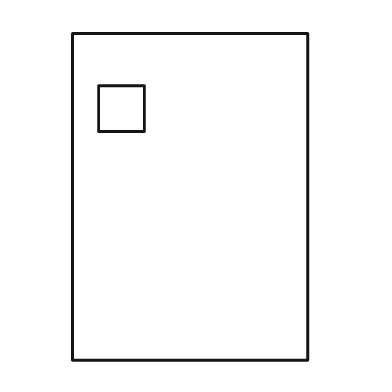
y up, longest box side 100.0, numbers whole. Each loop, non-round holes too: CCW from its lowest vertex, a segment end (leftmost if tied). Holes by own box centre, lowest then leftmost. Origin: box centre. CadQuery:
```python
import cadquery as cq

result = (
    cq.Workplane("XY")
    .moveTo(-36.0, -50.0)
    .lineTo(36.0, -50.0)
    .lineTo(36.0, 50.0)
    .lineTo(-36.0, 50.0)
    .close()
    .moveTo(-28.0, 20.0)
    .lineTo(-14.0, 20.0)
    .lineTo(-14.0, 34.0)
    .lineTo(-28.0, 34.0)
    .close()
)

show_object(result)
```